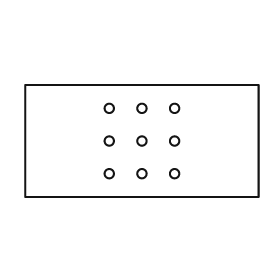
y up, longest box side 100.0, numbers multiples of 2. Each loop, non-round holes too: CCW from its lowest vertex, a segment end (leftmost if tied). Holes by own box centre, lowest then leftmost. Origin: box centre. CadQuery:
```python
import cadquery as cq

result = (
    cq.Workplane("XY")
    .moveTo(-50.0, -24.0)
    .lineTo(50.0, -24.0)
    .lineTo(50.0, 24.0)
    .lineTo(-50.0, 24.0)
    .close()
    .moveTo(-14.0, -14.0)
    .circle(2.0)
    .moveTo(0.0, -14.0)
    .circle(2.0)
    .moveTo(14.0, -14.0)
    .circle(2.0)
    .moveTo(-14.0, 0.0)
    .circle(2.0)
    .moveTo(0.0, 0.0)
    .circle(2.0)
    .moveTo(14.0, 0.0)
    .circle(2.0)
    .moveTo(-14.0, 14.0)
    .circle(2.0)
    .moveTo(0.0, 14.0)
    .circle(2.0)
    .moveTo(14.0, 14.0)
    .circle(2.0)
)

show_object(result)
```